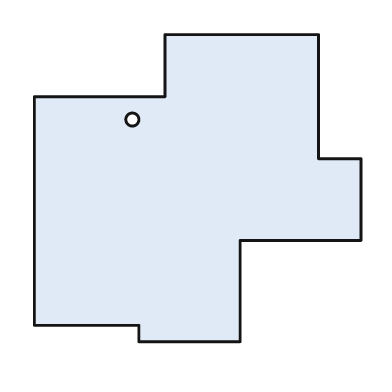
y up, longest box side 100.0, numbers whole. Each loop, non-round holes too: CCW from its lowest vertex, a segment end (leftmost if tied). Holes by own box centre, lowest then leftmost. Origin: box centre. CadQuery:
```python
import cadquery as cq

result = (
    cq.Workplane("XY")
    .moveTo(-18.0, -47.0)
    .lineTo(13.0, -47.0)
    .lineTo(13.0, -16.0)
    .lineTo(50.0, -16.0)
    .lineTo(50.0, 9.0)
    .lineTo(37.0, 9.0)
    .lineTo(37.0, 47.0)
    .lineTo(-10.0, 47.0)
    .lineTo(-10.0, 28.0)
    .lineTo(-50.0, 28.0)
    .lineTo(-50.0, -42.0)
    .lineTo(-18.0, -42.0)
    .close()
    .moveTo(-20.0, 21.0)
    .circle(2.0)
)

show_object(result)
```